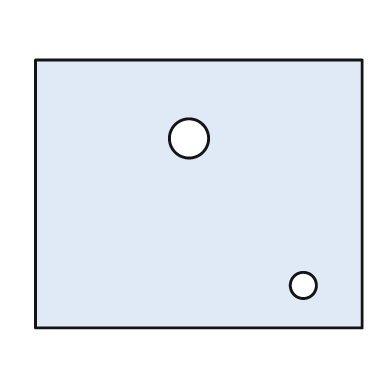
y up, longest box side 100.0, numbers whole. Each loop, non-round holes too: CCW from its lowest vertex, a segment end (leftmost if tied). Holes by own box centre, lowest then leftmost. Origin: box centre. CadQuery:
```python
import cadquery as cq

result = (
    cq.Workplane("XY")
    .moveTo(-50.0, -41.0)
    .lineTo(50.0, -41.0)
    .lineTo(50.0, 41.0)
    .lineTo(-50.0, 41.0)
    .close()
    .moveTo(32.0, -28.0)
    .circle(4.0)
    .moveTo(-3.0, 17.0)
    .circle(6.0)
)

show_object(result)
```